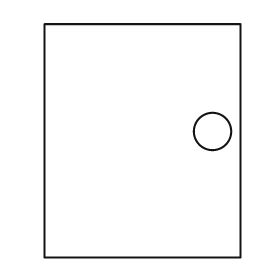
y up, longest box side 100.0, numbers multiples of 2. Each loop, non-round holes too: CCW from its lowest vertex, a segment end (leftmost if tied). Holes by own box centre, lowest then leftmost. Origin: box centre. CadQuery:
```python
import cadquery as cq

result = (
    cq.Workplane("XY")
    .moveTo(-42.0, -50.0)
    .lineTo(42.0, -50.0)
    .lineTo(42.0, 50.0)
    .lineTo(-42.0, 50.0)
    .close()
    .moveTo(30.0, 4.0)
    .circle(8.0)
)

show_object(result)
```